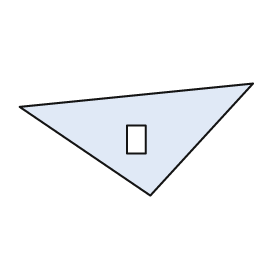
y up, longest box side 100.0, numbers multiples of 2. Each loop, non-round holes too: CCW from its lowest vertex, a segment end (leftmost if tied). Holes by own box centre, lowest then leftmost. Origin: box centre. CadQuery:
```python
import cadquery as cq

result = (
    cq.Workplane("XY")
    .moveTo(6.0, -24.0)
    .lineTo(50.0, 24.0)
    .lineTo(-50.0, 14.0)
    .close()
    .moveTo(-4.0, -6.0)
    .lineTo(4.0, -6.0)
    .lineTo(4.0, 6.0)
    .lineTo(-4.0, 6.0)
    .close()
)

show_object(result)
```